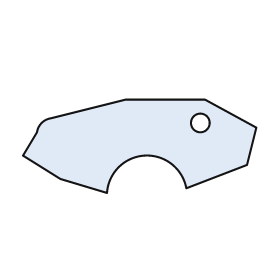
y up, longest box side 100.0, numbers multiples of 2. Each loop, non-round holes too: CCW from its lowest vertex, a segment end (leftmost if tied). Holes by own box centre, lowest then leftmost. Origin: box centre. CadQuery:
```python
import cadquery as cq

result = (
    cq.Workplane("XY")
    .moveTo(-14.0, -20.0)
    .threePointArc((2.0, -4.0), (20.0, -18.0))
    .lineTo(46.0, -8.0)
    .lineTo(50.0, 8.0)
    .lineTo(28.0, 20.0)
    .lineTo(-6.0, 20.0)
    .lineTo(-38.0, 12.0)
    .threePointArc((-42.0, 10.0), (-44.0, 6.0))
    .lineTo(-50.0, -4.0)
    .lineTo(-34.0, -14.0)
    .close()
    .moveTo(26.0, 10.0)
    .circle(4.0)
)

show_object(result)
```